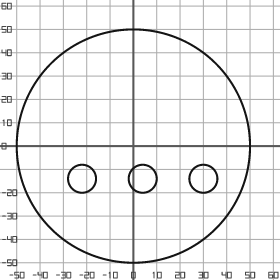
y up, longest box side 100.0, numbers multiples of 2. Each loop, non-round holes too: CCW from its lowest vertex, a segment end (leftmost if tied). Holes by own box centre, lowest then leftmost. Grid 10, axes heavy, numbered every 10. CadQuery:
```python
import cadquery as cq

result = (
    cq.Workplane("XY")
    .moveTo(0.0, 0.0)
    .circle(50.0)
    .moveTo(-22.0, -14.0)
    .circle(6.0)
    .moveTo(4.0, -14.0)
    .circle(6.0)
    .moveTo(30.0, -14.0)
    .circle(6.0)
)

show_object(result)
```